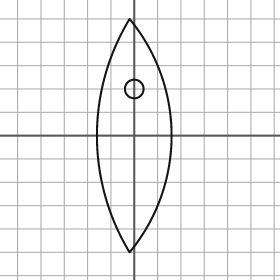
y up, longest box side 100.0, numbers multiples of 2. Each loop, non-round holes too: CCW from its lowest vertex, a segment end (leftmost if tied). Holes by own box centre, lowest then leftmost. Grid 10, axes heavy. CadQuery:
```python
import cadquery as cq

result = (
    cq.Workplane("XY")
    .moveTo(-2.0, -50.0)
    .threePointArc((16.0, 0.0), (-2.0, 50.0))
    .threePointArc((-16.0, 0.0), (-2.0, -50.0))
    .close()
    .moveTo(0.0, 20.0)
    .circle(4.0)
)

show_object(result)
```